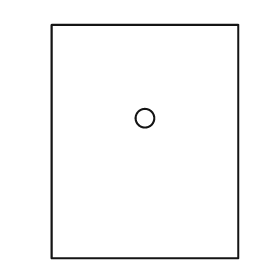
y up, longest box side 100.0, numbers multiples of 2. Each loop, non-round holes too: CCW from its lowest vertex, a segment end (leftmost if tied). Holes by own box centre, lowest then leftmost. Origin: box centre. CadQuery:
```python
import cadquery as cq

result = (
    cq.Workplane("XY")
    .moveTo(-40.0, -50.0)
    .lineTo(40.0, -50.0)
    .lineTo(40.0, 50.0)
    .lineTo(-40.0, 50.0)
    .close()
    .moveTo(0.0, 10.0)
    .circle(4.0)
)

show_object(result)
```